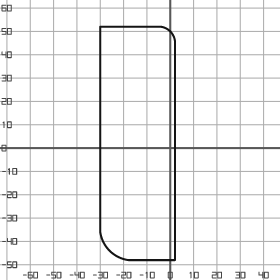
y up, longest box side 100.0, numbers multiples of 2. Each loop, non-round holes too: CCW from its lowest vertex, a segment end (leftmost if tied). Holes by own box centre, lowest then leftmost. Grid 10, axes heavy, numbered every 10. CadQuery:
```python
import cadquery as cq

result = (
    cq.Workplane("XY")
    .moveTo(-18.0, -48.0)
    .lineTo(2.0, -48.0)
    .lineTo(2.0, 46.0)
    .threePointArc((0.0, 50.0), (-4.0, 52.0))
    .lineTo(-30.0, 52.0)
    .lineTo(-30.0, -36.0)
    .threePointArc((-26.0, -44.0), (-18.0, -48.0))
    .close()
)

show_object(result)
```